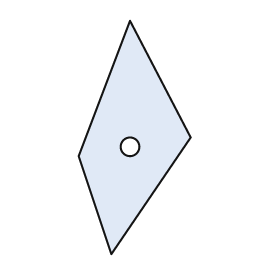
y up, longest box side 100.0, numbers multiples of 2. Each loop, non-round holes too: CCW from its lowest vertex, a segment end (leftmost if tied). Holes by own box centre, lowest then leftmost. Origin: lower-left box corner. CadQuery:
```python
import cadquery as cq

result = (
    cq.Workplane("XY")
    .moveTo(14.0, 0.0)
    .lineTo(48.0, 50.0)
    .lineTo(22.0, 100.0)
    .lineTo(0.0, 42.0)
    .close()
    .moveTo(22.0, 46.0)
    .circle(4.0)
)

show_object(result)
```